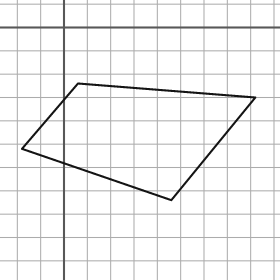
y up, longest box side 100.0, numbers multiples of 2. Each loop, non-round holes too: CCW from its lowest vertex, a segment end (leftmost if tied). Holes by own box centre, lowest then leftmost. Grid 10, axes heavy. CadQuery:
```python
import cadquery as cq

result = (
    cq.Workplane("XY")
    .moveTo(46.0, -74.0)
    .lineTo(82.0, -30.0)
    .lineTo(6.0, -24.0)
    .lineTo(-18.0, -52.0)
    .close()
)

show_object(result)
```